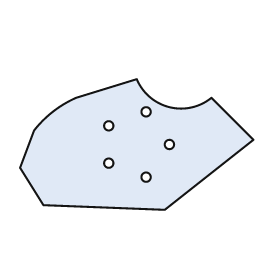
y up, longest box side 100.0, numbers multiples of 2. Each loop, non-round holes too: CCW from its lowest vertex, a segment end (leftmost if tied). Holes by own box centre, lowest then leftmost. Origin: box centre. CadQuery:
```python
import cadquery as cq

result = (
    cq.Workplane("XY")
    .moveTo(12.0, -28.0)
    .lineTo(50.0, 2.0)
    .lineTo(32.0, 20.0)
    .threePointArc((14.0, 16.0), (0.0, 28.0))
    .lineTo(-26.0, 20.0)
    .threePointArc((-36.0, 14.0), (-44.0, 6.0))
    .lineTo(-50.0, -10.0)
    .lineTo(-40.0, -26.0)
    .close()
    .moveTo(4.0, -14.0)
    .circle(2.0)
    .moveTo(-12.0, -8.0)
    .circle(2.0)
    .moveTo(14.0, 0.0)
    .circle(2.0)
    .moveTo(-12.0, 8.0)
    .circle(2.0)
    .moveTo(4.0, 14.0)
    .circle(2.0)
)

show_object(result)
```